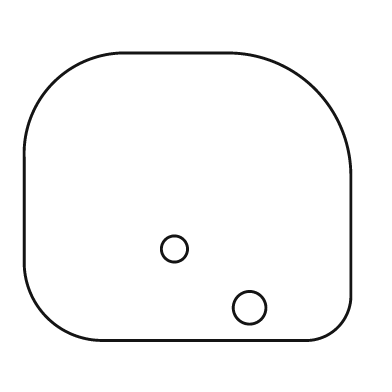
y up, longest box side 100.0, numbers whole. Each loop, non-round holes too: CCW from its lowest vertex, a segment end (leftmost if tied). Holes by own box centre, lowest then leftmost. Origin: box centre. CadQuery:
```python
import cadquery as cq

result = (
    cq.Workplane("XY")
    .moveTo(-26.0, -44.0)
    .lineTo(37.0, -44.0)
    .threePointArc((46.0, -40.0), (50.0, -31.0))
    .lineTo(50.0, 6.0)
    .threePointArc((39.0, 33.0), (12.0, 44.0))
    .lineTo(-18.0, 44.0)
    .threePointArc((-41.0, 35.0), (-50.0, 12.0))
    .lineTo(-50.0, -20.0)
    .threePointArc((-43.0, -37.0), (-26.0, -44.0))
    .close()
    .moveTo(19.0, -34.0)
    .circle(5.0)
    .moveTo(-4.0, -16.0)
    .circle(4.0)
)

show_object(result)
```